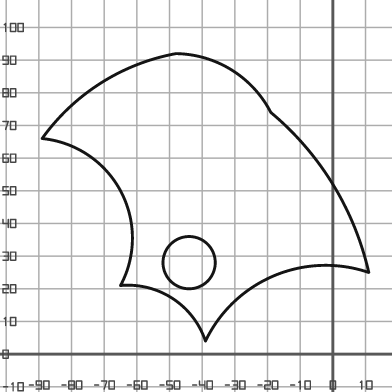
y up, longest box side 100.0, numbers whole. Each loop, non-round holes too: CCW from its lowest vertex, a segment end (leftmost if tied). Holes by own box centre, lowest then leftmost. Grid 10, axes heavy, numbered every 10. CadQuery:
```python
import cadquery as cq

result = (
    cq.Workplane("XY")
    .moveTo(-39.0, 4.0)
    .threePointArc((-18.0, 24.0), (11.0, 25.0))
    .threePointArc((0.0, 52.0), (-19.0, 74.0))
    .threePointArc((-31.0, 87.0), (-48.0, 92.0))
    .threePointArc((-71.0, 83.0), (-89.0, 66.0))
    .threePointArc((-65.0, 50.0), (-65.0, 21.0))
    .threePointArc((-49.0, 17.0), (-39.0, 4.0))
    .close()
    .moveTo(-44.0, 28.0)
    .circle(8.0)
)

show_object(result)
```